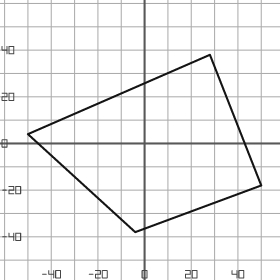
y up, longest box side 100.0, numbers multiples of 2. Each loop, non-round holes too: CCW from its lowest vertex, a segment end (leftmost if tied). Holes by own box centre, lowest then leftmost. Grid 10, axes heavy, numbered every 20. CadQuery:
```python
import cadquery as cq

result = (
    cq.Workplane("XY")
    .moveTo(-4.0, -38.0)
    .lineTo(50.0, -18.0)
    .lineTo(28.0, 38.0)
    .lineTo(-50.0, 4.0)
    .close()
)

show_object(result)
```